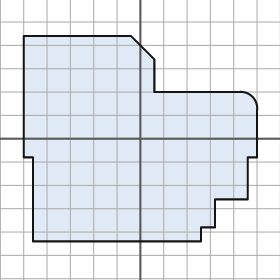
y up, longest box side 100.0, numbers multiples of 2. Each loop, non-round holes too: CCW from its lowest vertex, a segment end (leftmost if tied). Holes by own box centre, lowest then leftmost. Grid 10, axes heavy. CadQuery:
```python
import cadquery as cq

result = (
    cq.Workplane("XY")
    .moveTo(-46.0, -44.0)
    .lineTo(26.0, -44.0)
    .lineTo(26.0, -38.0)
    .lineTo(32.0, -38.0)
    .lineTo(32.0, -26.0)
    .lineTo(46.0, -26.0)
    .lineTo(46.0, -8.0)
    .lineTo(50.0, -8.0)
    .lineTo(50.0, 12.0)
    .threePointArc((48.0, 18.0), (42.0, 20.0))
    .lineTo(6.0, 20.0)
    .lineTo(6.0, 34.0)
    .lineTo(-4.0, 44.0)
    .lineTo(-50.0, 44.0)
    .lineTo(-50.0, -8.0)
    .lineTo(-46.0, -8.0)
    .close()
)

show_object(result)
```